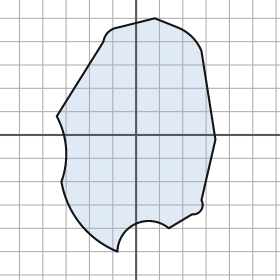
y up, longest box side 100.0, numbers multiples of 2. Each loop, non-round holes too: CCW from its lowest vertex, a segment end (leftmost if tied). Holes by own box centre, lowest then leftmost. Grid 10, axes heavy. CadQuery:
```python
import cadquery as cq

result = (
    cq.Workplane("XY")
    .moveTo(-8.0, -50.0)
    .threePointArc((0.0, -38.0), (14.0, -40.0))
    .lineTo(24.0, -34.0)
    .threePointArc((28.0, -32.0), (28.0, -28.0))
    .lineTo(34.0, -2.0)
    .lineTo(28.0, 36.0)
    .threePointArc((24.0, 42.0), (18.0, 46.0))
    .lineTo(8.0, 50.0)
    .lineTo(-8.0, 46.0)
    .threePointArc((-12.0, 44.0), (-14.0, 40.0))
    .lineTo(-34.0, 8.0)
    .threePointArc((-30.0, -6.0), (-32.0, -20.0))
    .threePointArc((-24.0, -38.0), (-8.0, -50.0))
    .close()
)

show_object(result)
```